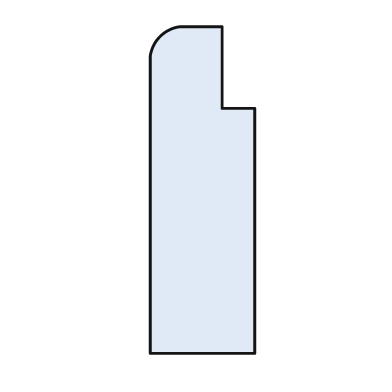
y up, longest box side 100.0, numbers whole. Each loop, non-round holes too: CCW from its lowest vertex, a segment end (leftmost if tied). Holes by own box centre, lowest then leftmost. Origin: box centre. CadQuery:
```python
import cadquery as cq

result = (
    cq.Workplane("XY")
    .moveTo(-16.0, -50.0)
    .lineTo(16.0, -50.0)
    .lineTo(16.0, 25.0)
    .lineTo(6.0, 25.0)
    .lineTo(6.0, 50.0)
    .lineTo(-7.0, 50.0)
    .threePointArc((-13.0, 47.0), (-16.0, 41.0))
    .close()
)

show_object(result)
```